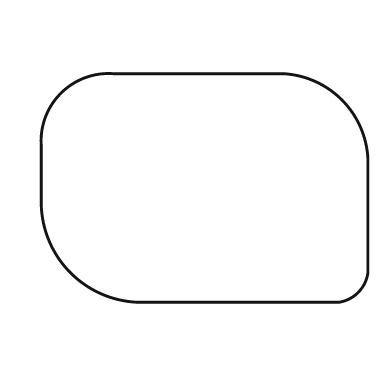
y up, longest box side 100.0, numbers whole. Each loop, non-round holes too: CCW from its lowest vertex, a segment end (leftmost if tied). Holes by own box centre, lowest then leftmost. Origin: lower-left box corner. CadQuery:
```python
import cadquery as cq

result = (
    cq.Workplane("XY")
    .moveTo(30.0, 0.0)
    .lineTo(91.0, 0.0)
    .threePointArc((97.0, 3.0), (100.0, 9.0))
    .lineTo(100.0, 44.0)
    .threePointArc((92.0, 62.0), (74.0, 70.0))
    .lineTo(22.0, 70.0)
    .threePointArc((6.0, 64.0), (0.0, 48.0))
    .lineTo(0.0, 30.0)
    .threePointArc((9.0, 9.0), (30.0, 0.0))
    .close()
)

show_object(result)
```